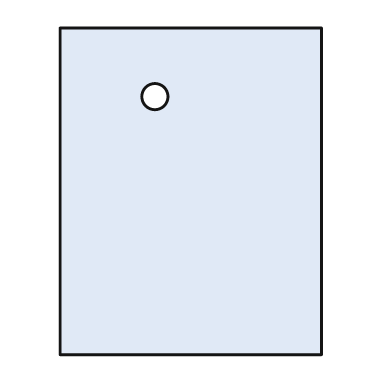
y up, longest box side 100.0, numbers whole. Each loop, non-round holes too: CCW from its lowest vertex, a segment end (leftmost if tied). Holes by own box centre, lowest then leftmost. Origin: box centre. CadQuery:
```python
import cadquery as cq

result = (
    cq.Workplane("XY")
    .moveTo(-40.0, -50.0)
    .lineTo(40.0, -50.0)
    .lineTo(40.0, 50.0)
    .lineTo(-40.0, 50.0)
    .close()
    .moveTo(-11.0, 29.0)
    .circle(4.0)
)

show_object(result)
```